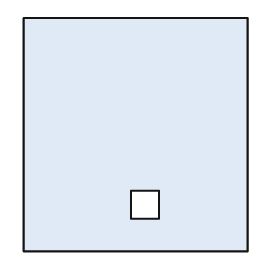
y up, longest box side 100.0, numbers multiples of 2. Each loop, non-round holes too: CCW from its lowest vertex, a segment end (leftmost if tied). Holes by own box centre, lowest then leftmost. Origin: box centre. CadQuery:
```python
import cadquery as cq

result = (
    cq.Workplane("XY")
    .moveTo(-48.0, -50.0)
    .lineTo(48.0, -50.0)
    .lineTo(48.0, 50.0)
    .lineTo(-48.0, 50.0)
    .close()
    .moveTo(-2.0, -36.0)
    .lineTo(10.0, -36.0)
    .lineTo(10.0, -24.0)
    .lineTo(-2.0, -24.0)
    .close()
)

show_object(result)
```